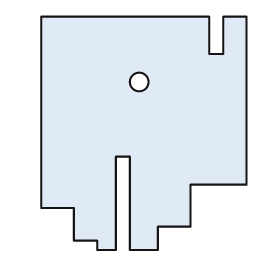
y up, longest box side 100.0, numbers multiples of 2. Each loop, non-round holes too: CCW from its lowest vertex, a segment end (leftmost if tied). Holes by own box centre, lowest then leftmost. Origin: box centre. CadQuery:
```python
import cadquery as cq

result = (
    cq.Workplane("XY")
    .moveTo(-20.0, -50.0)
    .lineTo(-12.0, -50.0)
    .lineTo(-12.0, -10.0)
    .lineTo(-6.0, -10.0)
    .lineTo(-6.0, -50.0)
    .lineTo(6.0, -50.0)
    .lineTo(6.0, -40.0)
    .lineTo(20.0, -40.0)
    .lineTo(20.0, -22.0)
    .lineTo(44.0, -22.0)
    .lineTo(44.0, 50.0)
    .lineTo(34.0, 50.0)
    .lineTo(34.0, 34.0)
    .lineTo(28.0, 34.0)
    .lineTo(28.0, 50.0)
    .lineTo(-44.0, 50.0)
    .lineTo(-44.0, -32.0)
    .lineTo(-30.0, -32.0)
    .lineTo(-30.0, -46.0)
    .lineTo(-20.0, -46.0)
    .close()
    .moveTo(-2.0, 22.0)
    .circle(4.0)
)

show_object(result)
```